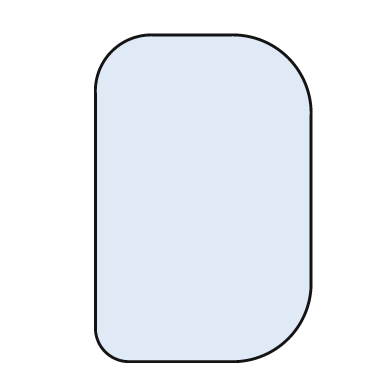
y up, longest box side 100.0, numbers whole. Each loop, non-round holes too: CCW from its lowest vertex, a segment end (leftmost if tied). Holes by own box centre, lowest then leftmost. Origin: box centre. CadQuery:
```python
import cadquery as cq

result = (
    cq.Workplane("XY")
    .moveTo(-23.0, -50.0)
    .lineTo(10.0, -50.0)
    .threePointArc((26.0, -43.0), (33.0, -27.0))
    .lineTo(33.0, 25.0)
    .threePointArc((26.0, 43.0), (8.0, 50.0))
    .lineTo(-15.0, 50.0)
    .threePointArc((-28.0, 45.0), (-33.0, 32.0))
    .lineTo(-33.0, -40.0)
    .threePointArc((-30.0, -47.0), (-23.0, -50.0))
    .close()
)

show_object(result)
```